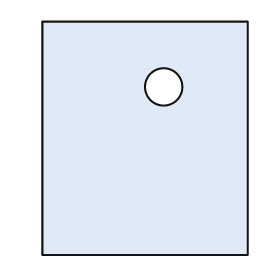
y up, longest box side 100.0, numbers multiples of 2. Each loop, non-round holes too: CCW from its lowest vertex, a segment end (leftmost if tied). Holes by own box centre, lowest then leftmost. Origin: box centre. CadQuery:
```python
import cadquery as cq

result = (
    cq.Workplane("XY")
    .moveTo(-44.0, -50.0)
    .lineTo(44.0, -50.0)
    .lineTo(44.0, 50.0)
    .lineTo(-44.0, 50.0)
    .close()
    .moveTo(8.0, 22.0)
    .circle(8.0)
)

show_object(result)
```